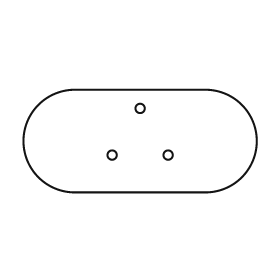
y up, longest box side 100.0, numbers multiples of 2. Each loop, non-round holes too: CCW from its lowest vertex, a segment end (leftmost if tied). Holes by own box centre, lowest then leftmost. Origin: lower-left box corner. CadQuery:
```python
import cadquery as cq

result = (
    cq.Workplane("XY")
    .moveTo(22.0, 0.0)
    .lineTo(78.0, 0.0)
    .threePointArc((100.0, 22.0), (78.0, 44.0))
    .lineTo(22.0, 44.0)
    .threePointArc((0.0, 22.0), (22.0, 0.0))
    .close()
    .moveTo(38.0, 16.0)
    .circle(2.0)
    .moveTo(62.0, 16.0)
    .circle(2.0)
    .moveTo(50.0, 36.0)
    .circle(2.0)
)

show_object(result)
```